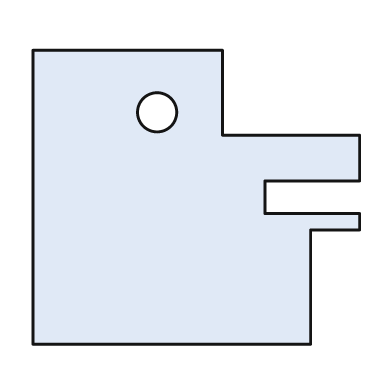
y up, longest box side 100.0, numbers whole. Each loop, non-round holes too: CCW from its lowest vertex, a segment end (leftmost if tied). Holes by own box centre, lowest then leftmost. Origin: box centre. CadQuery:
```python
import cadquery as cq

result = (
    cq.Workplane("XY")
    .moveTo(-50.0, -45.0)
    .lineTo(35.0, -45.0)
    .lineTo(35.0, -10.0)
    .lineTo(50.0, -10.0)
    .lineTo(50.0, -5.0)
    .lineTo(21.0, -5.0)
    .lineTo(21.0, 5.0)
    .lineTo(50.0, 5.0)
    .lineTo(50.0, 19.0)
    .lineTo(8.0, 19.0)
    .lineTo(8.0, 45.0)
    .lineTo(-50.0, 45.0)
    .close()
    .moveTo(-12.0, 26.0)
    .circle(6.0)
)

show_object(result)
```